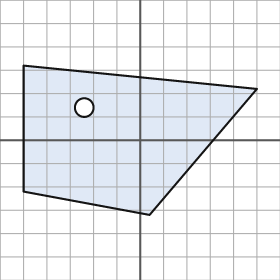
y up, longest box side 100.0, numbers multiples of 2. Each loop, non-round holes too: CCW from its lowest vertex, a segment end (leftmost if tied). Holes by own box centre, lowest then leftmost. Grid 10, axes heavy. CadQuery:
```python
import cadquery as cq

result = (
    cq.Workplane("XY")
    .moveTo(4.0, -32.0)
    .lineTo(50.0, 22.0)
    .lineTo(-50.0, 32.0)
    .lineTo(-50.0, -22.0)
    .close()
    .moveTo(-24.0, 14.0)
    .circle(4.0)
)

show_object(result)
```